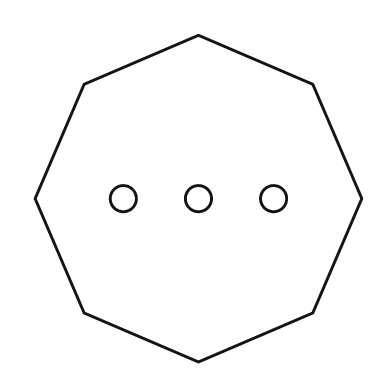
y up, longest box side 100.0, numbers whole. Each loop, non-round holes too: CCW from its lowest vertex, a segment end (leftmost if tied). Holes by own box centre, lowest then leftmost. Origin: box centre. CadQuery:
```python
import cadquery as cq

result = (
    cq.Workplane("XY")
    .moveTo(0.0, -50.0)
    .lineTo(35.0, -35.0)
    .lineTo(50.0, 0.0)
    .lineTo(35.0, 35.0)
    .lineTo(0.0, 50.0)
    .lineTo(-35.0, 35.0)
    .lineTo(-50.0, 0.0)
    .lineTo(-35.0, -35.0)
    .close()
    .moveTo(-23.0, 0.0)
    .circle(4.0)
    .moveTo(0.0, 0.0)
    .circle(4.0)
    .moveTo(23.0, 0.0)
    .circle(4.0)
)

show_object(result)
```